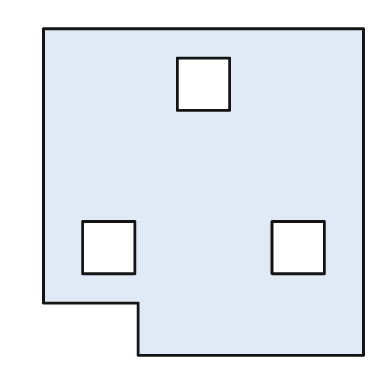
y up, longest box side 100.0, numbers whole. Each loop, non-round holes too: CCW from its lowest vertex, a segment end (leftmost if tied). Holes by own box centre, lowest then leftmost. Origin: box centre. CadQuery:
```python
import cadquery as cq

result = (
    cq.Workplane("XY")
    .moveTo(-20.0, -50.0)
    .lineTo(49.0, -50.0)
    .lineTo(49.0, 50.0)
    .lineTo(-49.0, 50.0)
    .lineTo(-49.0, -34.0)
    .lineTo(-20.0, -34.0)
    .close()
    .moveTo(-37.0, -25.0)
    .lineTo(-21.0, -25.0)
    .lineTo(-21.0, -9.0)
    .lineTo(-37.0, -9.0)
    .close()
    .moveTo(21.0, -25.0)
    .lineTo(37.0, -25.0)
    .lineTo(37.0, -9.0)
    .lineTo(21.0, -9.0)
    .close()
    .moveTo(-8.0, 25.0)
    .lineTo(8.0, 25.0)
    .lineTo(8.0, 41.0)
    .lineTo(-8.0, 41.0)
    .close()
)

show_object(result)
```